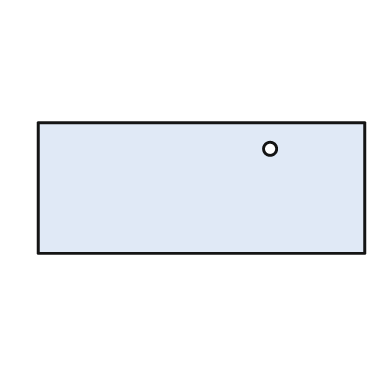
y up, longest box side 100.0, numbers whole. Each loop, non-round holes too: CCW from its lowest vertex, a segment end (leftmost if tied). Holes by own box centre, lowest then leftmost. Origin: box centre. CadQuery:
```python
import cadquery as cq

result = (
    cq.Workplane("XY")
    .moveTo(-50.0, -20.0)
    .lineTo(50.0, -20.0)
    .lineTo(50.0, 20.0)
    .lineTo(-50.0, 20.0)
    .close()
    .moveTo(21.0, 12.0)
    .circle(2.0)
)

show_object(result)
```